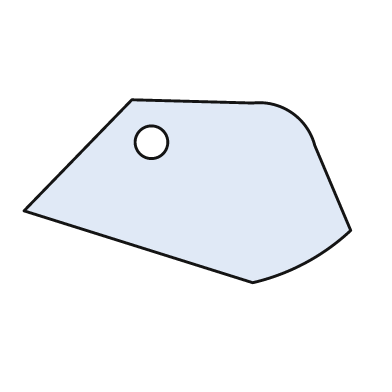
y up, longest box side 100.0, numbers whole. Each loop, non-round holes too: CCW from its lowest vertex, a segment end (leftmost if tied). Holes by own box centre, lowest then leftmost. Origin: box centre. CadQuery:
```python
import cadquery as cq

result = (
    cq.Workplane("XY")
    .moveTo(20.0, -28.0)
    .threePointArc((36.0, -22.0), (50.0, -12.0))
    .lineTo(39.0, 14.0)
    .threePointArc((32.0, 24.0), (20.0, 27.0))
    .lineTo(-17.0, 28.0)
    .lineTo(-50.0, -6.0)
    .close()
    .moveTo(-11.0, 15.0)
    .circle(5.0)
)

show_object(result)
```